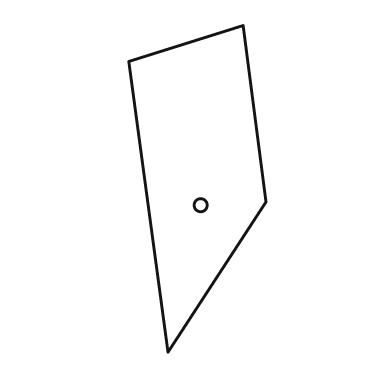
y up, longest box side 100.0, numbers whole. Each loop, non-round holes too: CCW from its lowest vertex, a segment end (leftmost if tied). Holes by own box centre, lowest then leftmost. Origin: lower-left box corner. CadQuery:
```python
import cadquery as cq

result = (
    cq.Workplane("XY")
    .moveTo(12.0, 0.0)
    .lineTo(42.0, 46.0)
    .lineTo(35.0, 100.0)
    .lineTo(0.0, 89.0)
    .close()
    .moveTo(22.0, 45.0)
    .circle(2.0)
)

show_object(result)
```